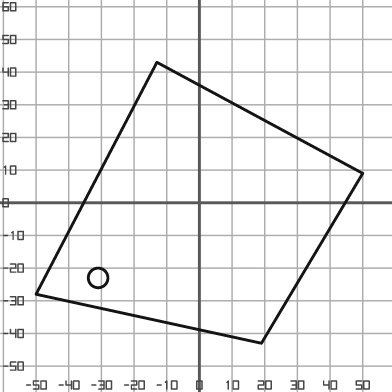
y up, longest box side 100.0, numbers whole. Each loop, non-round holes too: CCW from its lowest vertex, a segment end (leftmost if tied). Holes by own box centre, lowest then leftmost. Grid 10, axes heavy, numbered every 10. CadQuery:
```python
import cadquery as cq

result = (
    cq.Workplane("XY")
    .moveTo(19.0, -43.0)
    .lineTo(50.0, 9.0)
    .lineTo(-13.0, 43.0)
    .lineTo(-50.0, -28.0)
    .close()
    .moveTo(-31.0, -23.0)
    .circle(3.0)
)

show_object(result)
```